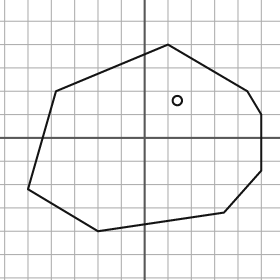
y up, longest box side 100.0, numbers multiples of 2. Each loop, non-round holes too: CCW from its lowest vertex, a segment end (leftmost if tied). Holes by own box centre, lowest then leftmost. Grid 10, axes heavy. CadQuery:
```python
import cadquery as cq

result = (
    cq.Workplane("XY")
    .moveTo(-20.0, -40.0)
    .lineTo(34.0, -32.0)
    .lineTo(50.0, -14.0)
    .lineTo(50.0, 10.0)
    .lineTo(44.0, 20.0)
    .lineTo(10.0, 40.0)
    .lineTo(-38.0, 20.0)
    .lineTo(-50.0, -22.0)
    .close()
    .moveTo(14.0, 16.0)
    .circle(2.0)
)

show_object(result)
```